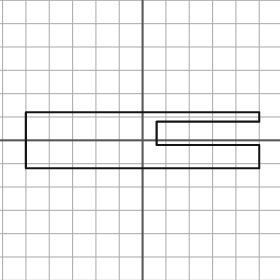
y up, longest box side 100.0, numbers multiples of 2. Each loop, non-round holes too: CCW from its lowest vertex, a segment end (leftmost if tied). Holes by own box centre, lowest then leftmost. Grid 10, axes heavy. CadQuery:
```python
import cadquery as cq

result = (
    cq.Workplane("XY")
    .moveTo(-50.0, -12.0)
    .lineTo(50.0, -12.0)
    .lineTo(50.0, -2.0)
    .lineTo(6.0, -2.0)
    .lineTo(6.0, 8.0)
    .lineTo(50.0, 8.0)
    .lineTo(50.0, 12.0)
    .lineTo(-50.0, 12.0)
    .close()
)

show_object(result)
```